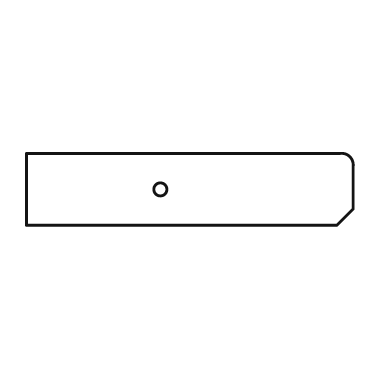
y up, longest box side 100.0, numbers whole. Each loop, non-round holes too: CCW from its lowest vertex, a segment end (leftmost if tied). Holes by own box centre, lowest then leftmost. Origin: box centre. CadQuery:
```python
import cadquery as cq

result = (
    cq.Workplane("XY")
    .moveTo(-50.0, -11.0)
    .lineTo(45.0, -11.0)
    .lineTo(50.0, -6.0)
    .lineTo(50.0, 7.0)
    .threePointArc((49.0, 10.0), (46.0, 11.0))
    .lineTo(-50.0, 11.0)
    .close()
    .moveTo(-9.0, 0.0)
    .circle(2.0)
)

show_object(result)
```